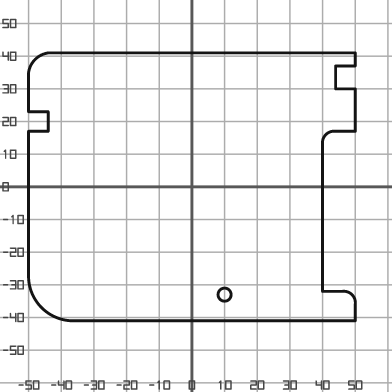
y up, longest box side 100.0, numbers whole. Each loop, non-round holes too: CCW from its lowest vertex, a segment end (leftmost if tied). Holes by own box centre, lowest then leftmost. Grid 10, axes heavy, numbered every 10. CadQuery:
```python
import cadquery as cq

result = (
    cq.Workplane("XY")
    .moveTo(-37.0, -41.0)
    .lineTo(50.0, -41.0)
    .lineTo(50.0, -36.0)
    .threePointArc((49.0, -33.0), (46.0, -32.0))
    .lineTo(40.0, -32.0)
    .lineTo(40.0, 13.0)
    .threePointArc((41.0, 16.0), (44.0, 17.0))
    .lineTo(50.0, 17.0)
    .lineTo(50.0, 30.0)
    .lineTo(44.0, 30.0)
    .lineTo(44.0, 37.0)
    .lineTo(50.0, 37.0)
    .lineTo(50.0, 41.0)
    .lineTo(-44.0, 41.0)
    .threePointArc((-48.0, 39.0), (-50.0, 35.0))
    .lineTo(-50.0, 23.0)
    .lineTo(-44.0, 23.0)
    .lineTo(-44.0, 17.0)
    .lineTo(-50.0, 17.0)
    .lineTo(-50.0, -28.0)
    .threePointArc((-46.0, -37.0), (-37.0, -41.0))
    .close()
    .moveTo(10.0, -33.0)
    .circle(2.0)
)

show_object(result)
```